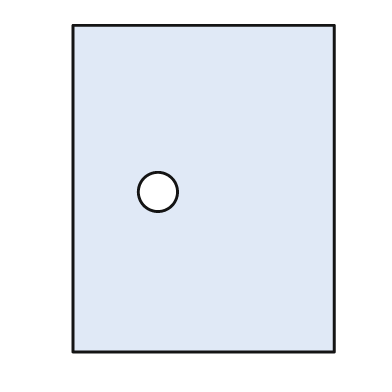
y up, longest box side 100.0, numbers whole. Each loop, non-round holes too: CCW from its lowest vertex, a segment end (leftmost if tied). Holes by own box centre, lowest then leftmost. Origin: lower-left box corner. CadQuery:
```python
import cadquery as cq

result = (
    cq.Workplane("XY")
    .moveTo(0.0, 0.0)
    .lineTo(80.0, 0.0)
    .lineTo(80.0, 100.0)
    .lineTo(0.0, 100.0)
    .close()
    .moveTo(26.0, 49.0)
    .circle(6.0)
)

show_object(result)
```